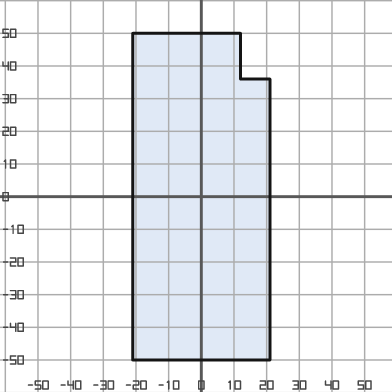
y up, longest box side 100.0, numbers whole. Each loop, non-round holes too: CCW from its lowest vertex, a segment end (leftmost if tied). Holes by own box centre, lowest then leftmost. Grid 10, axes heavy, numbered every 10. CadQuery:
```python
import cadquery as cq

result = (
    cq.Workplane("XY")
    .moveTo(-21.0, -50.0)
    .lineTo(21.0, -50.0)
    .lineTo(21.0, 36.0)
    .lineTo(12.0, 36.0)
    .lineTo(12.0, 50.0)
    .lineTo(-21.0, 50.0)
    .close()
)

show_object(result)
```